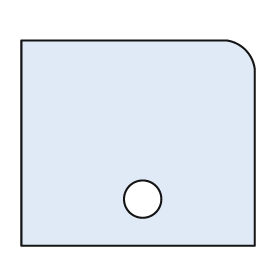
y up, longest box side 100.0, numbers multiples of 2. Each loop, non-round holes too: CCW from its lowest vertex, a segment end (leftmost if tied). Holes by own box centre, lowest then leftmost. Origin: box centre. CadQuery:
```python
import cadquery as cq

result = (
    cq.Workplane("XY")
    .moveTo(-50.0, -44.0)
    .lineTo(50.0, -44.0)
    .lineTo(50.0, 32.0)
    .threePointArc((46.0, 40.0), (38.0, 44.0))
    .lineTo(-50.0, 44.0)
    .close()
    .moveTo(2.0, -24.0)
    .circle(8.0)
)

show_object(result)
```